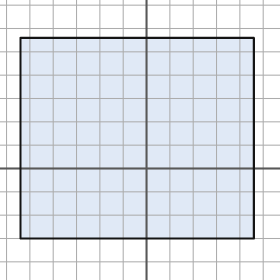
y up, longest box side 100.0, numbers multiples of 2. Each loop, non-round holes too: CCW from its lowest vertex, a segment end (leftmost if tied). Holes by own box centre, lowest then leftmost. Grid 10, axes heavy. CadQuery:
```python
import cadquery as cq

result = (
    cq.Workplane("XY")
    .moveTo(-54.0, -30.0)
    .lineTo(46.0, -30.0)
    .lineTo(46.0, 56.0)
    .lineTo(-54.0, 56.0)
    .close()
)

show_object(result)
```